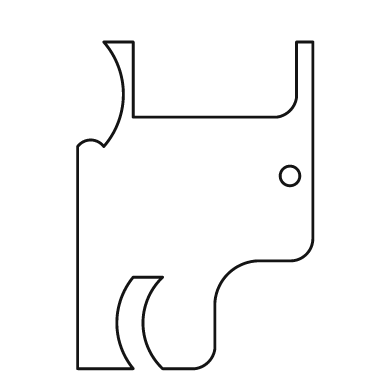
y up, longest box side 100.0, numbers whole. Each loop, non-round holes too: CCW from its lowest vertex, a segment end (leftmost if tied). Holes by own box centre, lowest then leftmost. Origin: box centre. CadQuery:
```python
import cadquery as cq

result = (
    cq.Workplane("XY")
    .moveTo(-36.0, -50.0)
    .lineTo(-19.0, -50.0)
    .threePointArc((-24.0, -36.0), (-19.0, -22.0))
    .lineTo(-10.0, -22.0)
    .threePointArc((-16.0, -36.0), (-10.0, -50.0))
    .lineTo(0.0, -50.0)
    .threePointArc((4.0, -48.0), (6.0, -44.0))
    .lineTo(6.0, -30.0)
    .threePointArc((10.0, -21.0), (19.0, -17.0))
    .lineTo(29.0, -17.0)
    .threePointArc((34.0, -15.0), (36.0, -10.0))
    .lineTo(36.0, 50.0)
    .lineTo(31.0, 50.0)
    .lineTo(31.0, 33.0)
    .threePointArc((29.0, 29.0), (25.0, 27.0))
    .lineTo(-19.0, 27.0)
    .lineTo(-19.0, 50.0)
    .lineTo(-28.0, 50.0)
    .threePointArc((-22.0, 34.0), (-28.0, 18.0))
    .threePointArc((-32.0, 20.0), (-36.0, 18.0))
    .close()
    .moveTo(29.0, 9.0)
    .circle(3.0)
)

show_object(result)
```